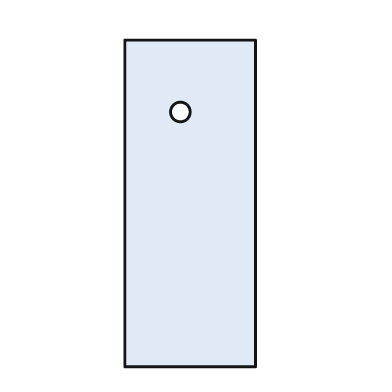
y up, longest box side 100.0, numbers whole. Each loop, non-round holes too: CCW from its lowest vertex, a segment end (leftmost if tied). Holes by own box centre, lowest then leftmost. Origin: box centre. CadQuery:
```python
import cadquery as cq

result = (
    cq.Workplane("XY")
    .moveTo(-20.0, -50.0)
    .lineTo(20.0, -50.0)
    .lineTo(20.0, 50.0)
    .lineTo(-20.0, 50.0)
    .close()
    .moveTo(-3.0, 28.0)
    .circle(3.0)
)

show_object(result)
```